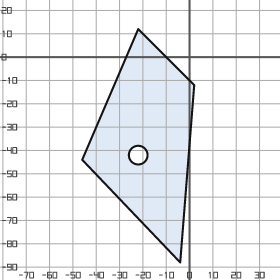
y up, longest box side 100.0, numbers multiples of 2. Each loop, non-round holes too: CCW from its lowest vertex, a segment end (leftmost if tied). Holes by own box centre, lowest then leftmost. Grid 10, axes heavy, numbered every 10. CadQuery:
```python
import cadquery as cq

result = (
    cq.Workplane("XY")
    .moveTo(-4.0, -88.0)
    .lineTo(2.0, -12.0)
    .lineTo(-22.0, 12.0)
    .lineTo(-46.0, -44.0)
    .close()
    .moveTo(-22.0, -42.0)
    .circle(4.0)
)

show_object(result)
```